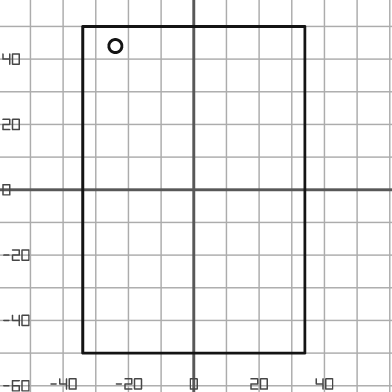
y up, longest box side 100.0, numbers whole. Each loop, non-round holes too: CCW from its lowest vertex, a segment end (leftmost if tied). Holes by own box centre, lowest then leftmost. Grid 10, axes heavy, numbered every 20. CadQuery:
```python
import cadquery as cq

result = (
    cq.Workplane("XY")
    .moveTo(-34.0, -50.0)
    .lineTo(34.0, -50.0)
    .lineTo(34.0, 50.0)
    .lineTo(-34.0, 50.0)
    .close()
    .moveTo(-24.0, 44.0)
    .circle(2.0)
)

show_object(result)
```